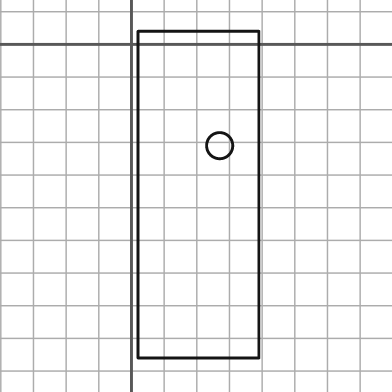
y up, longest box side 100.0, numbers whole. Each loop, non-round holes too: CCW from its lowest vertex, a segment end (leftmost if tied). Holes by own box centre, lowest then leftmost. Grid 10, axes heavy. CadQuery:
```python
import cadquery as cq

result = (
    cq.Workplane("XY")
    .moveTo(2.0, -96.0)
    .lineTo(39.0, -96.0)
    .lineTo(39.0, 4.0)
    .lineTo(2.0, 4.0)
    .close()
    .moveTo(27.0, -31.0)
    .circle(4.0)
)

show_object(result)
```